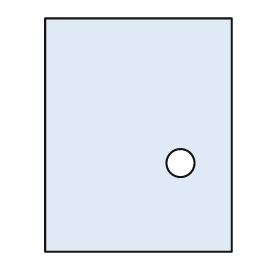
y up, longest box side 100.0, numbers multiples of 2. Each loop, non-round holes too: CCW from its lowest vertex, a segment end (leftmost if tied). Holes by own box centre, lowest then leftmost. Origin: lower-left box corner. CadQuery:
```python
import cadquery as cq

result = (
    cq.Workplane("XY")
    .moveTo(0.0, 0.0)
    .lineTo(80.0, 0.0)
    .lineTo(80.0, 100.0)
    .lineTo(0.0, 100.0)
    .close()
    .moveTo(58.0, 38.0)
    .circle(6.0)
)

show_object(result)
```